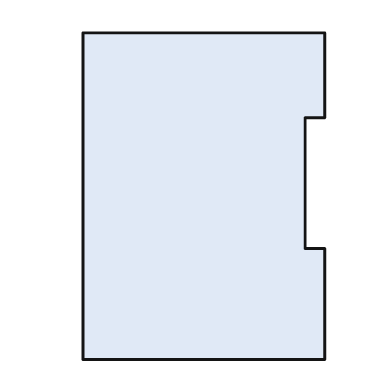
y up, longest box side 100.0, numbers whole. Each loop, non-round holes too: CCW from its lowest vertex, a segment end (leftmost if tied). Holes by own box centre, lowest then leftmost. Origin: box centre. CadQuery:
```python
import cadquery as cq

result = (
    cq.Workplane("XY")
    .moveTo(-37.0, -50.0)
    .lineTo(37.0, -50.0)
    .lineTo(37.0, -16.0)
    .lineTo(31.0, -16.0)
    .lineTo(31.0, 24.0)
    .lineTo(37.0, 24.0)
    .lineTo(37.0, 50.0)
    .lineTo(-37.0, 50.0)
    .close()
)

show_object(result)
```